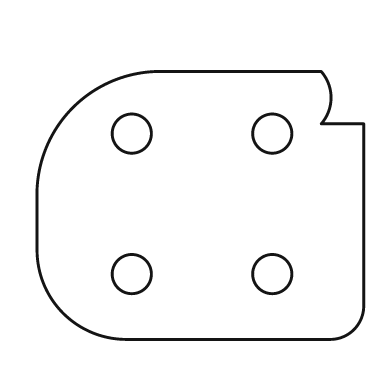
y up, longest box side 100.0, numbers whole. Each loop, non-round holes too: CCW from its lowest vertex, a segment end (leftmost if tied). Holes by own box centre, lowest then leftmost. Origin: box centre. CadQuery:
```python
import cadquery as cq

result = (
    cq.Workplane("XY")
    .moveTo(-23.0, -41.0)
    .lineTo(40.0, -41.0)
    .threePointArc((47.0, -38.0), (50.0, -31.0))
    .lineTo(50.0, 25.0)
    .lineTo(37.0, 25.0)
    .threePointArc((40.0, 33.0), (37.0, 41.0))
    .lineTo(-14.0, 41.0)
    .threePointArc((-39.0, 30.0), (-50.0, 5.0))
    .lineTo(-50.0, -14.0)
    .threePointArc((-42.0, -33.0), (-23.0, -41.0))
    .close()
    .moveTo(-21.0, -21.0)
    .circle(6.0)
    .moveTo(22.0, -21.0)
    .circle(6.0)
    .moveTo(-21.0, 22.0)
    .circle(6.0)
    .moveTo(22.0, 22.0)
    .circle(6.0)
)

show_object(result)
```